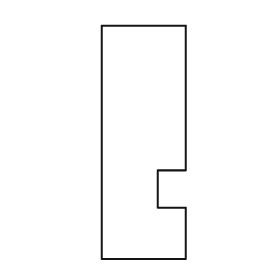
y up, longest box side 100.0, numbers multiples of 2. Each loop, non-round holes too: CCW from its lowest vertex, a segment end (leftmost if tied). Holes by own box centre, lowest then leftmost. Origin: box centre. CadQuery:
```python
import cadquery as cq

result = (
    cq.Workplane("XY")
    .moveTo(-18.0, -50.0)
    .lineTo(18.0, -50.0)
    .lineTo(18.0, -28.0)
    .lineTo(6.0, -28.0)
    .lineTo(6.0, -12.0)
    .lineTo(18.0, -12.0)
    .lineTo(18.0, 50.0)
    .lineTo(-18.0, 50.0)
    .close()
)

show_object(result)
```